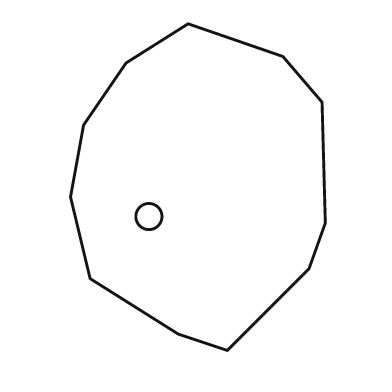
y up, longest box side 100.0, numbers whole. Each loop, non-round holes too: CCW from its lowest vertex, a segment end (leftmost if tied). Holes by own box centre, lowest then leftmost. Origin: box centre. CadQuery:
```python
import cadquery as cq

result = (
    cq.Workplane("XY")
    .moveTo(9.0, -50.0)
    .lineTo(34.0, -25.0)
    .lineTo(39.0, -11.0)
    .lineTo(38.0, 26.0)
    .lineTo(26.0, 40.0)
    .lineTo(-3.0, 50.0)
    .lineTo(-22.0, 38.0)
    .lineTo(-35.0, 19.0)
    .lineTo(-39.0, -3.0)
    .lineTo(-33.0, -28.0)
    .lineTo(-6.0, -45.0)
    .close()
    .moveTo(-15.0, -9.0)
    .circle(4.0)
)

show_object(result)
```